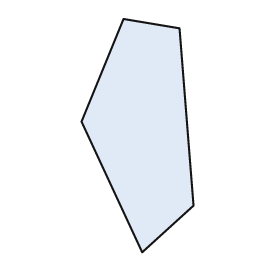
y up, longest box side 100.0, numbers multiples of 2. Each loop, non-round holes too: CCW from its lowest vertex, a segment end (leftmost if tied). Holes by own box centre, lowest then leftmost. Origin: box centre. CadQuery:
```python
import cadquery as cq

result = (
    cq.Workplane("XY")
    .moveTo(2.0, -50.0)
    .lineTo(24.0, -30.0)
    .lineTo(18.0, 46.0)
    .lineTo(-6.0, 50.0)
    .lineTo(-24.0, 6.0)
    .close()
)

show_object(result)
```